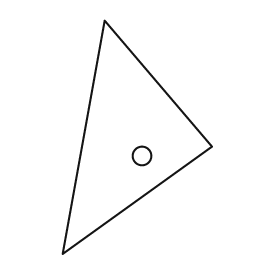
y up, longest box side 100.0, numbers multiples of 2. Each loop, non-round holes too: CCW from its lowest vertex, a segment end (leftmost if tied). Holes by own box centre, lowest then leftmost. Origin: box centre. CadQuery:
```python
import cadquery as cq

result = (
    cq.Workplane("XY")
    .moveTo(-32.0, -50.0)
    .lineTo(32.0, -4.0)
    .lineTo(-14.0, 50.0)
    .close()
    .moveTo(2.0, -8.0)
    .circle(4.0)
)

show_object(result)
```